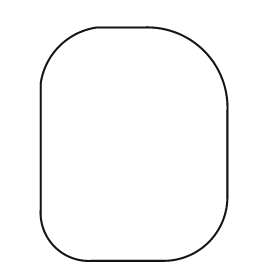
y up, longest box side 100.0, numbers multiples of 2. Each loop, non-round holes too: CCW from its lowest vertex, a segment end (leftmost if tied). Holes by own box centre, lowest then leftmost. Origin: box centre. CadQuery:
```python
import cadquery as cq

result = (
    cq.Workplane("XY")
    .moveTo(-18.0, -50.0)
    .lineTo(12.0, -50.0)
    .threePointArc((32.0, -42.0), (40.0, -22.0))
    .lineTo(40.0, 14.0)
    .threePointArc((30.0, 40.0), (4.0, 50.0))
    .lineTo(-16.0, 50.0)
    .threePointArc((-32.0, 42.0), (-40.0, 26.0))
    .lineTo(-40.0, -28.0)
    .threePointArc((-34.0, -44.0), (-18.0, -50.0))
    .close()
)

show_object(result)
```